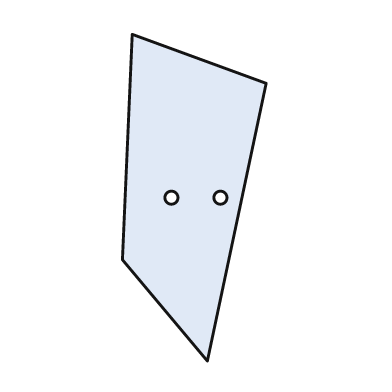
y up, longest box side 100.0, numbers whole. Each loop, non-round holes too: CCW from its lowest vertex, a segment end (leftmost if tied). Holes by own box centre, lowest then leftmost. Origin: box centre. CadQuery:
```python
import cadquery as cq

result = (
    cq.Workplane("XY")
    .moveTo(4.0, -50.0)
    .lineTo(22.0, 35.0)
    .lineTo(-19.0, 50.0)
    .lineTo(-22.0, -19.0)
    .close()
    .moveTo(-7.0, 0.0)
    .circle(2.0)
    .moveTo(8.0, 0.0)
    .circle(2.0)
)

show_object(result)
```